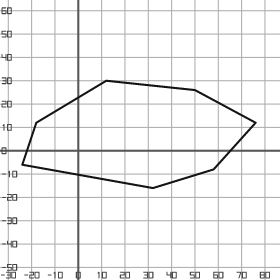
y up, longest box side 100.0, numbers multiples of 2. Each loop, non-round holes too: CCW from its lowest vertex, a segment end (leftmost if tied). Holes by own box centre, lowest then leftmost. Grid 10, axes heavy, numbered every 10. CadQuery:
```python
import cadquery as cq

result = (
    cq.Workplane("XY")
    .moveTo(32.0, -16.0)
    .lineTo(58.0, -8.0)
    .lineTo(76.0, 12.0)
    .lineTo(50.0, 26.0)
    .lineTo(12.0, 30.0)
    .lineTo(-18.0, 12.0)
    .lineTo(-24.0, -6.0)
    .close()
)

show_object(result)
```